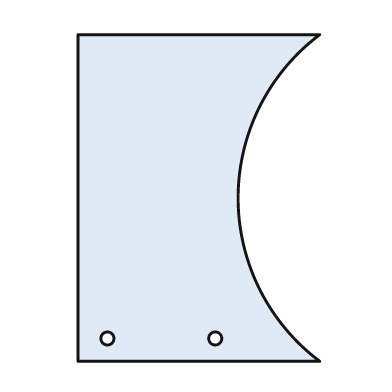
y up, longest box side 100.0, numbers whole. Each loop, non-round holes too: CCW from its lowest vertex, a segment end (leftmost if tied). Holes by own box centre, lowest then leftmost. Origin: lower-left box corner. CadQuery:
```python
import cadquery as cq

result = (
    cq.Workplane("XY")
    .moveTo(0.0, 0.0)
    .lineTo(74.0, 0.0)
    .threePointArc((49.0, 50.0), (74.0, 100.0))
    .lineTo(0.0, 100.0)
    .close()
    .moveTo(9.0, 7.0)
    .circle(2.0)
    .moveTo(42.0, 7.0)
    .circle(2.0)
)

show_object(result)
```